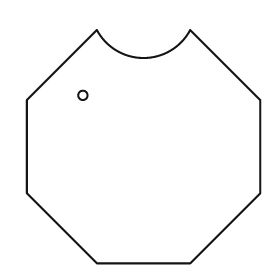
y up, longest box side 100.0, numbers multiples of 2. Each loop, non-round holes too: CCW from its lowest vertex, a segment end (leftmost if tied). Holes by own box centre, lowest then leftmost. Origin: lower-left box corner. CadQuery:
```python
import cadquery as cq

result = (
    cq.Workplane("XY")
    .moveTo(30.0, 0.0)
    .lineTo(70.0, 0.0)
    .lineTo(100.0, 30.0)
    .lineTo(100.0, 70.0)
    .lineTo(70.0, 100.0)
    .threePointArc((50.0, 88.0), (30.0, 100.0))
    .lineTo(0.0, 70.0)
    .lineTo(0.0, 30.0)
    .close()
    .moveTo(24.0, 72.0)
    .circle(2.0)
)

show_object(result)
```